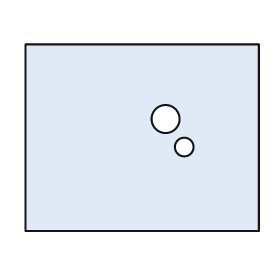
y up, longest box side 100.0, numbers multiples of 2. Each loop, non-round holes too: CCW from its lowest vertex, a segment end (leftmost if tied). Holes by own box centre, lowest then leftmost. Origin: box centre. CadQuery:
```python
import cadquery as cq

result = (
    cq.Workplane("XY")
    .moveTo(-50.0, -40.0)
    .lineTo(50.0, -40.0)
    .lineTo(50.0, 40.0)
    .lineTo(-50.0, 40.0)
    .close()
    .moveTo(18.0, -4.0)
    .circle(4.0)
    .moveTo(10.0, 8.0)
    .circle(6.0)
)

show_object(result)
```